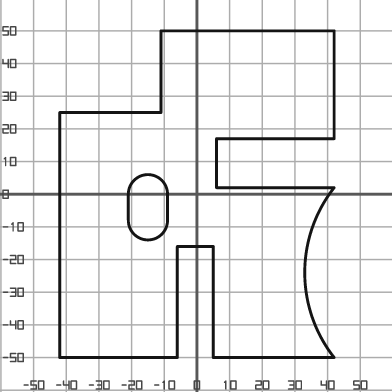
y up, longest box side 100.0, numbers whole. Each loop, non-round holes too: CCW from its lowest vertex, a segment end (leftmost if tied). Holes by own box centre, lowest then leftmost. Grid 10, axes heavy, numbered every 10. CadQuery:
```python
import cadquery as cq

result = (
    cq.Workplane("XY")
    .moveTo(-42.0, -50.0)
    .lineTo(-6.0, -50.0)
    .lineTo(-6.0, -16.0)
    .lineTo(5.0, -16.0)
    .lineTo(5.0, -50.0)
    .lineTo(42.0, -50.0)
    .threePointArc((33.0, -24.0), (42.0, 2.0))
    .lineTo(6.0, 2.0)
    .lineTo(6.0, 17.0)
    .lineTo(42.0, 17.0)
    .lineTo(42.0, 50.0)
    .lineTo(-11.0, 50.0)
    .lineTo(-11.0, 25.0)
    .lineTo(-42.0, 25.0)
    .close()
    .moveTo(-21.0, -8.0)
    .threePointArc((-15.0, -14.0), (-9.0, -8.0))
    .lineTo(-9.0, 0.0)
    .threePointArc((-15.0, 6.0), (-21.0, 0.0))
    .close()
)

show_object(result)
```